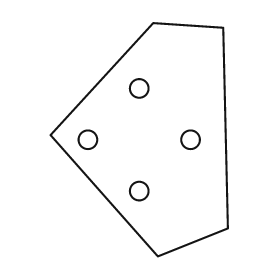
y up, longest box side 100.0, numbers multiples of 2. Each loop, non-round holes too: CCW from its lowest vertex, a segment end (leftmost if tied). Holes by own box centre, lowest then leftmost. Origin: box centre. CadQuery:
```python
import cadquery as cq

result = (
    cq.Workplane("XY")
    .moveTo(8.0, -50.0)
    .lineTo(38.0, -38.0)
    .lineTo(36.0, 48.0)
    .lineTo(6.0, 50.0)
    .lineTo(-38.0, 2.0)
    .close()
    .moveTo(0.0, -22.0)
    .circle(4.0)
    .moveTo(-22.0, 0.0)
    .circle(4.0)
    .moveTo(22.0, 0.0)
    .circle(4.0)
    .moveTo(0.0, 22.0)
    .circle(4.0)
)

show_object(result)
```